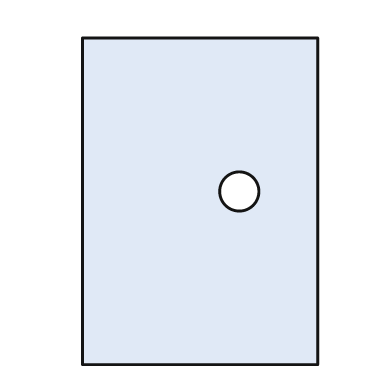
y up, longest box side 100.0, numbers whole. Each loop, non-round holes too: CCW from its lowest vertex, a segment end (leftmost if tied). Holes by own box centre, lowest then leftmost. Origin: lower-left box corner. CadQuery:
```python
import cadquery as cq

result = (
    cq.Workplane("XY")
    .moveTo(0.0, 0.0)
    .lineTo(72.0, 0.0)
    .lineTo(72.0, 100.0)
    .lineTo(0.0, 100.0)
    .close()
    .moveTo(48.0, 53.0)
    .circle(6.0)
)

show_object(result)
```